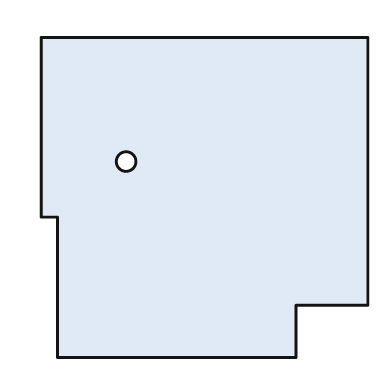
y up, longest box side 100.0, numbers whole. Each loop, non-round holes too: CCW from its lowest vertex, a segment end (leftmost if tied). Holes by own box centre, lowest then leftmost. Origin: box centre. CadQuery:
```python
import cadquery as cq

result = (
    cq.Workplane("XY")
    .moveTo(-45.0, -49.0)
    .lineTo(28.0, -49.0)
    .lineTo(28.0, -33.0)
    .lineTo(50.0, -33.0)
    .lineTo(50.0, 49.0)
    .lineTo(-50.0, 49.0)
    .lineTo(-50.0, -6.0)
    .lineTo(-45.0, -6.0)
    .close()
    .moveTo(-24.0, 11.0)
    .circle(3.0)
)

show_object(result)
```